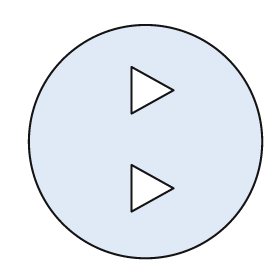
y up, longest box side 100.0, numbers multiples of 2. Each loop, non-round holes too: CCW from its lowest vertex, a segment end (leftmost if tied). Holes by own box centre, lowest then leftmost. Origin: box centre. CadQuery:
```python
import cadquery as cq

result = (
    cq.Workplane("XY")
    .moveTo(0.0, 0.0)
    .circle(50.0)
    .moveTo(-6.0, -30.0)
    .lineTo(12.0, -20.0)
    .lineTo(-6.0, -10.0)
    .close()
    .moveTo(-6.0, 12.0)
    .lineTo(12.0, 22.0)
    .lineTo(-6.0, 32.0)
    .close()
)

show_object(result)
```